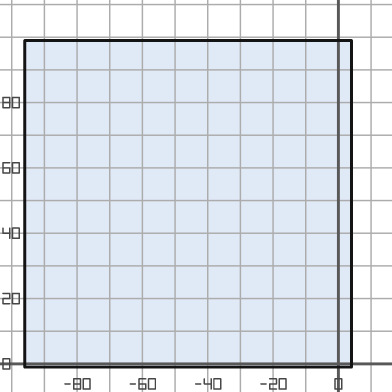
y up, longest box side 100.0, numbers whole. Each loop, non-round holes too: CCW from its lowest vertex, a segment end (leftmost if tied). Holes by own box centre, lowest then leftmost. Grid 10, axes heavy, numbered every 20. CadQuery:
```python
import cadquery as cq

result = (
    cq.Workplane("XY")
    .moveTo(-96.0, -1.0)
    .lineTo(4.0, -1.0)
    .lineTo(4.0, 99.0)
    .lineTo(-96.0, 99.0)
    .close()
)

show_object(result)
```